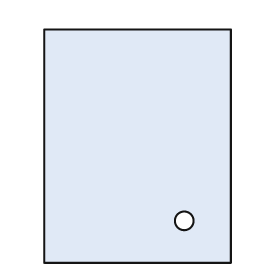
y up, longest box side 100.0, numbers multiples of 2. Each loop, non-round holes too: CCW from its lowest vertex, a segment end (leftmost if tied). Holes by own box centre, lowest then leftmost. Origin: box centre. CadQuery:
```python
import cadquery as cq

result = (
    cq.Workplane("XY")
    .moveTo(-40.0, -50.0)
    .lineTo(40.0, -50.0)
    .lineTo(40.0, 50.0)
    .lineTo(-40.0, 50.0)
    .close()
    .moveTo(20.0, -32.0)
    .circle(4.0)
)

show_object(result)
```